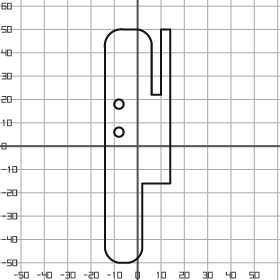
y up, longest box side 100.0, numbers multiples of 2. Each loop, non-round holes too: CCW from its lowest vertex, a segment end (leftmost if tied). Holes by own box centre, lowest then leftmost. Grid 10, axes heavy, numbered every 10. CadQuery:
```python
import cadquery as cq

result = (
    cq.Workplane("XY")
    .moveTo(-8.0, -50.0)
    .lineTo(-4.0, -50.0)
    .threePointArc((0.0, -48.0), (2.0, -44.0))
    .lineTo(2.0, -16.0)
    .lineTo(14.0, -16.0)
    .lineTo(14.0, 50.0)
    .lineTo(10.0, 50.0)
    .lineTo(10.0, 22.0)
    .lineTo(6.0, 22.0)
    .lineTo(6.0, 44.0)
    .threePointArc((4.0, 48.0), (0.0, 50.0))
    .lineTo(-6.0, 50.0)
    .threePointArc((-12.0, 48.0), (-14.0, 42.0))
    .lineTo(-14.0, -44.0)
    .threePointArc((-12.0, -48.0), (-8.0, -50.0))
    .close()
    .moveTo(-8.0, 6.0)
    .circle(2.0)
    .moveTo(-8.0, 18.0)
    .circle(2.0)
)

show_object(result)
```